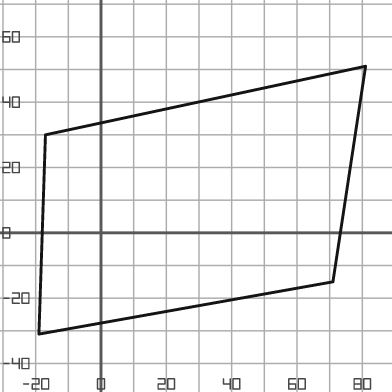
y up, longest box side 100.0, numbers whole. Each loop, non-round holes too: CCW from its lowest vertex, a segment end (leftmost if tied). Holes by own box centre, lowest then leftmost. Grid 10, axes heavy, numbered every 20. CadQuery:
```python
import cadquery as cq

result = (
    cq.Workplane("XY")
    .moveTo(-19.0, -31.0)
    .lineTo(71.0, -15.0)
    .lineTo(81.0, 51.0)
    .lineTo(-17.0, 30.0)
    .close()
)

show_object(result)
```